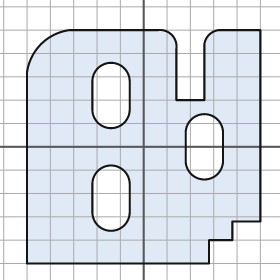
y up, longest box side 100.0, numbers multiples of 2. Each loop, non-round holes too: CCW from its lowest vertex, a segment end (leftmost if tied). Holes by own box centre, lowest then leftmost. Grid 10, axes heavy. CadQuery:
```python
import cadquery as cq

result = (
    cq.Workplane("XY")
    .moveTo(-50.0, -50.0)
    .lineTo(28.0, -50.0)
    .lineTo(28.0, -40.0)
    .lineTo(38.0, -40.0)
    .lineTo(38.0, -32.0)
    .lineTo(50.0, -32.0)
    .lineTo(50.0, 50.0)
    .lineTo(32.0, 50.0)
    .threePointArc((28.0, 48.0), (26.0, 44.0))
    .lineTo(26.0, 20.0)
    .lineTo(14.0, 20.0)
    .lineTo(14.0, 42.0)
    .threePointArc((12.0, 48.0), (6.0, 50.0))
    .lineTo(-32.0, 50.0)
    .threePointArc((-44.0, 44.0), (-50.0, 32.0))
    .close()
    .moveTo(-22.0, -28.0)
    .threePointArc((-14.0, -36.0), (-6.0, -28.0))
    .lineTo(-6.0, -16.0)
    .threePointArc((-14.0, -8.0), (-22.0, -16.0))
    .close()
    .moveTo(18.0, -6.0)
    .threePointArc((26.0, -14.0), (34.0, -6.0))
    .lineTo(34.0, 6.0)
    .threePointArc((26.0, 14.0), (18.0, 6.0))
    .close()
    .moveTo(-22.0, 16.0)
    .threePointArc((-14.0, 8.0), (-6.0, 16.0))
    .lineTo(-6.0, 28.0)
    .threePointArc((-14.0, 36.0), (-22.0, 28.0))
    .close()
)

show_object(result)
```